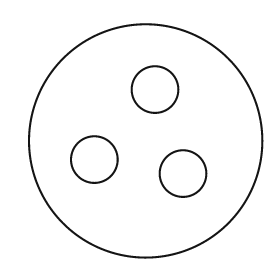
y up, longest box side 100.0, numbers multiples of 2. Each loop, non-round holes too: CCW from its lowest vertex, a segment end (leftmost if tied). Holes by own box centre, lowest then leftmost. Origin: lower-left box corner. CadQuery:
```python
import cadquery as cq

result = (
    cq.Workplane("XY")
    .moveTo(50.0, 50.0)
    .circle(50.0)
    .moveTo(66.0, 36.0)
    .circle(10.0)
    .moveTo(28.0, 42.0)
    .circle(10.0)
    .moveTo(54.0, 72.0)
    .circle(10.0)
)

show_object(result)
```